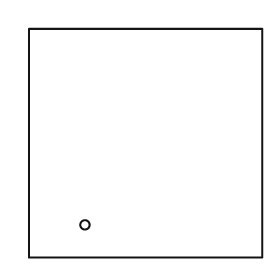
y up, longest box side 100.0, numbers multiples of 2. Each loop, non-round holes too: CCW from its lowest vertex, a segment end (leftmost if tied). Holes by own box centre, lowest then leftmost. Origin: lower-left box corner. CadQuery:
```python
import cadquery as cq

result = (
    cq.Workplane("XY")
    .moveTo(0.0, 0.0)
    .lineTo(100.0, 0.0)
    .lineTo(100.0, 98.0)
    .lineTo(0.0, 98.0)
    .close()
    .moveTo(24.0, 14.0)
    .circle(2.0)
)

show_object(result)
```